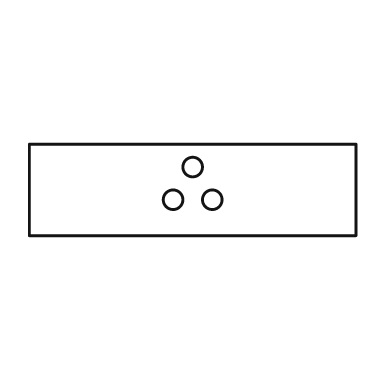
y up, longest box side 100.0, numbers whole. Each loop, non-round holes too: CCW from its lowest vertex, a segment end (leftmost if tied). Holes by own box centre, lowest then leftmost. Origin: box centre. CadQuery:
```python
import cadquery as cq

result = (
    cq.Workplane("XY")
    .moveTo(-50.0, -14.0)
    .lineTo(50.0, -14.0)
    .lineTo(50.0, 14.0)
    .lineTo(-50.0, 14.0)
    .close()
    .moveTo(-6.0, -3.0)
    .circle(3.0)
    .moveTo(6.0, -3.0)
    .circle(3.0)
    .moveTo(0.0, 7.0)
    .circle(3.0)
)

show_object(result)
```